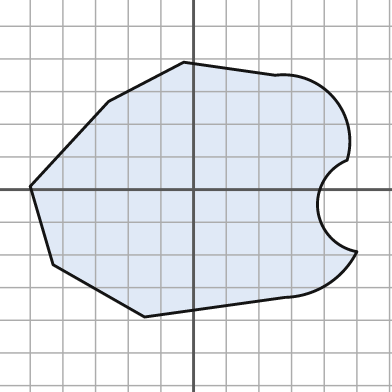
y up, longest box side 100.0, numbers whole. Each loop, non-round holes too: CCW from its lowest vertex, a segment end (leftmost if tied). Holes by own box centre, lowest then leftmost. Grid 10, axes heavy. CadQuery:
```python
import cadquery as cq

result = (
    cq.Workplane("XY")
    .moveTo(-15.0, -39.0)
    .lineTo(28.0, -33.0)
    .threePointArc((41.0, -29.0), (50.0, -19.0))
    .threePointArc((38.0, -6.0), (47.0, 9.0))
    .threePointArc((43.0, 28.0), (25.0, 35.0))
    .lineTo(-3.0, 39.0)
    .lineTo(-26.0, 27.0)
    .lineTo(-50.0, 1.0)
    .lineTo(-43.0, -23.0)
    .close()
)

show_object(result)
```